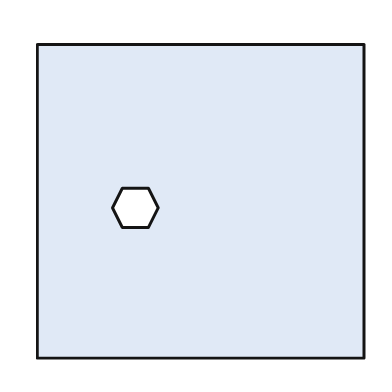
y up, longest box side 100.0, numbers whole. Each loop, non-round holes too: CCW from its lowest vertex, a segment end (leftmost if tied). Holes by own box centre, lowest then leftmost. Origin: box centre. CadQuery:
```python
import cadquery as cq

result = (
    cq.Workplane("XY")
    .moveTo(-50.0, -48.0)
    .lineTo(50.0, -48.0)
    .lineTo(50.0, 48.0)
    .lineTo(-50.0, 48.0)
    .close()
    .moveTo(-24.0, -8.0)
    .lineTo(-16.0, -8.0)
    .lineTo(-13.0, -2.0)
    .lineTo(-16.0, 4.0)
    .lineTo(-24.0, 4.0)
    .lineTo(-27.0, -2.0)
    .close()
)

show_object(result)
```